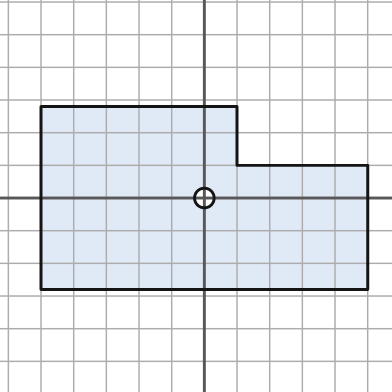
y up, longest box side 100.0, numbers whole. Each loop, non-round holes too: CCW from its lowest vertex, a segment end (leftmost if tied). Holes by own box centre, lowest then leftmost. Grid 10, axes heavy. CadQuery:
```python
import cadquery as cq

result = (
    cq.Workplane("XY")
    .moveTo(-50.0, -28.0)
    .lineTo(50.0, -28.0)
    .lineTo(50.0, 10.0)
    .lineTo(10.0, 10.0)
    .lineTo(10.0, 28.0)
    .lineTo(-50.0, 28.0)
    .close()
    .moveTo(0.0, 0.0)
    .circle(3.0)
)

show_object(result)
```